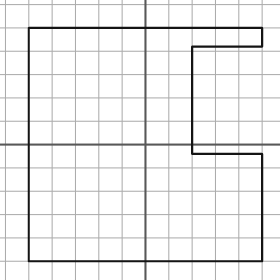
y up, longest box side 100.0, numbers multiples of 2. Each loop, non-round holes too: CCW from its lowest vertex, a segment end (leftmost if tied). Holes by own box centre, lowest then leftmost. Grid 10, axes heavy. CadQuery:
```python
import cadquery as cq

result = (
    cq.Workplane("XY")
    .moveTo(-50.0, -50.0)
    .lineTo(50.0, -50.0)
    .lineTo(50.0, -4.0)
    .lineTo(20.0, -4.0)
    .lineTo(20.0, 42.0)
    .lineTo(50.0, 42.0)
    .lineTo(50.0, 50.0)
    .lineTo(-50.0, 50.0)
    .close()
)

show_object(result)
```